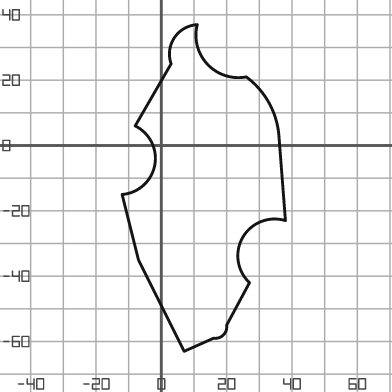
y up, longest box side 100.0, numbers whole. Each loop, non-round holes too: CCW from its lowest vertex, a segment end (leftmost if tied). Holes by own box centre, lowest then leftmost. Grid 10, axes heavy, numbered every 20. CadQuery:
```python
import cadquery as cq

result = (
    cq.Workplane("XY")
    .moveTo(7.0, -63.0)
    .lineTo(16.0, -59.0)
    .threePointArc((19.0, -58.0), (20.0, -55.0))
    .lineTo(27.0, -42.0)
    .threePointArc((25.0, -28.0), (38.0, -23.0))
    .lineTo(36.0, 3.0)
    .threePointArc((33.0, 13.0), (26.0, 21.0))
    .threePointArc((14.0, 25.0), (11.0, 37.0))
    .threePointArc((4.0, 33.0), (3.0, 25.0))
    .lineTo(-8.0, 6.0)
    .threePointArc((-2.0, -6.0), (-12.0, -15.0))
    .lineTo(-7.0, -35.0)
    .close()
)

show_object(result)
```